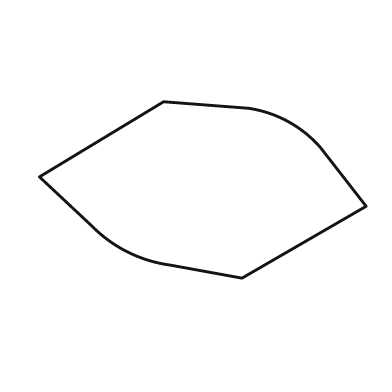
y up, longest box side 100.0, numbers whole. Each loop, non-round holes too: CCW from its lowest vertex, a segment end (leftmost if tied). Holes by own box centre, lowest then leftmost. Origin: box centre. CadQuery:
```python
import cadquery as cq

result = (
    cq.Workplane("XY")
    .moveTo(12.0, -27.0)
    .lineTo(50.0, -5.0)
    .lineTo(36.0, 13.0)
    .threePointArc((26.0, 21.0), (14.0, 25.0))
    .lineTo(-12.0, 27.0)
    .lineTo(-50.0, 4.0)
    .lineTo(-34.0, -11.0)
    .threePointArc((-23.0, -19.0), (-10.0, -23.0))
    .close()
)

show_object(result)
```